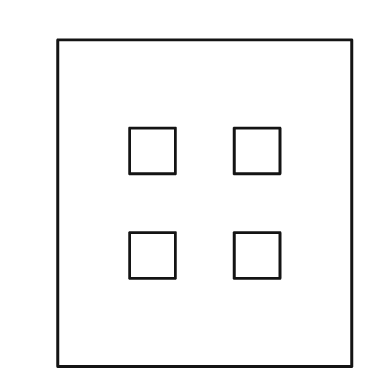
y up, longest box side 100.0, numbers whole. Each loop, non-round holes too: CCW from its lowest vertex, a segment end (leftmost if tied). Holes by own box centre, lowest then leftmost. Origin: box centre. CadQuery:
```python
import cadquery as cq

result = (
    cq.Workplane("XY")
    .moveTo(-45.0, -50.0)
    .lineTo(45.0, -50.0)
    .lineTo(45.0, 50.0)
    .lineTo(-45.0, 50.0)
    .close()
    .moveTo(-23.0, -23.0)
    .lineTo(-9.0, -23.0)
    .lineTo(-9.0, -9.0)
    .lineTo(-23.0, -9.0)
    .close()
    .moveTo(9.0, -23.0)
    .lineTo(23.0, -23.0)
    .lineTo(23.0, -9.0)
    .lineTo(9.0, -9.0)
    .close()
    .moveTo(-23.0, 9.0)
    .lineTo(-9.0, 9.0)
    .lineTo(-9.0, 23.0)
    .lineTo(-23.0, 23.0)
    .close()
    .moveTo(9.0, 9.0)
    .lineTo(23.0, 9.0)
    .lineTo(23.0, 23.0)
    .lineTo(9.0, 23.0)
    .close()
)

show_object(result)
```